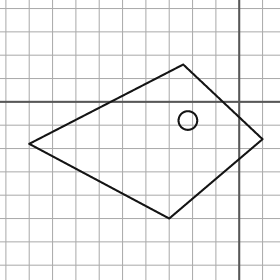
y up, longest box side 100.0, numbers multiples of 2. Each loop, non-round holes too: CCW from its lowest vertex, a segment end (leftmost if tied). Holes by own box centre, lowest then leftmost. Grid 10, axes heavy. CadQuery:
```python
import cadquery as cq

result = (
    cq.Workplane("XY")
    .moveTo(-30.0, -50.0)
    .lineTo(10.0, -16.0)
    .lineTo(-24.0, 16.0)
    .lineTo(-90.0, -18.0)
    .close()
    .moveTo(-22.0, -8.0)
    .circle(4.0)
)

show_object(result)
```